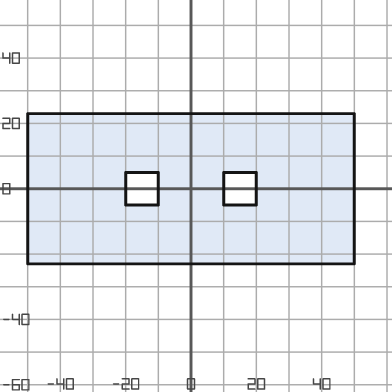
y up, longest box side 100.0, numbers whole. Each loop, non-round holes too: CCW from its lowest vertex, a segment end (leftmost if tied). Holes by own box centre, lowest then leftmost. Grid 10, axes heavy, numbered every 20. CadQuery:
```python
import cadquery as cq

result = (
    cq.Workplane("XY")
    .moveTo(-50.0, -23.0)
    .lineTo(50.0, -23.0)
    .lineTo(50.0, 23.0)
    .lineTo(-50.0, 23.0)
    .close()
    .moveTo(-20.0, -5.0)
    .lineTo(-10.0, -5.0)
    .lineTo(-10.0, 5.0)
    .lineTo(-20.0, 5.0)
    .close()
    .moveTo(10.0, -5.0)
    .lineTo(20.0, -5.0)
    .lineTo(20.0, 5.0)
    .lineTo(10.0, 5.0)
    .close()
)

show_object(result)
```